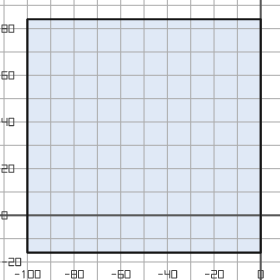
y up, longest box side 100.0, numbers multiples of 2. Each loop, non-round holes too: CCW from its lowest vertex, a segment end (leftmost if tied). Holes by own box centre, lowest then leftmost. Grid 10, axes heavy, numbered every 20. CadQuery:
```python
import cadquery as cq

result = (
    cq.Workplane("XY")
    .moveTo(-100.0, -16.0)
    .lineTo(0.0, -16.0)
    .lineTo(0.0, 84.0)
    .lineTo(-100.0, 84.0)
    .close()
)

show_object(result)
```